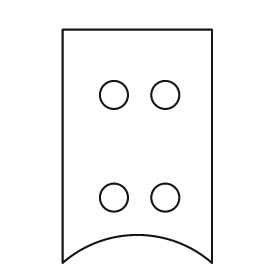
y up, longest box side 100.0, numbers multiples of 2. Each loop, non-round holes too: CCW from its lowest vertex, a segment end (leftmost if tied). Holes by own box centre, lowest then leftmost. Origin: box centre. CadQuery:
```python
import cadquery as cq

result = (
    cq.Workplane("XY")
    .moveTo(-32.0, -50.0)
    .threePointArc((0.0, -38.0), (32.0, -50.0))
    .lineTo(32.0, 50.0)
    .lineTo(-32.0, 50.0)
    .close()
    .moveTo(-10.0, -22.0)
    .circle(6.0)
    .moveTo(12.0, -22.0)
    .circle(6.0)
    .moveTo(-10.0, 22.0)
    .circle(6.0)
    .moveTo(12.0, 22.0)
    .circle(6.0)
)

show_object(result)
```